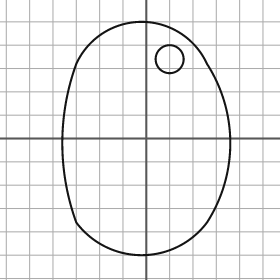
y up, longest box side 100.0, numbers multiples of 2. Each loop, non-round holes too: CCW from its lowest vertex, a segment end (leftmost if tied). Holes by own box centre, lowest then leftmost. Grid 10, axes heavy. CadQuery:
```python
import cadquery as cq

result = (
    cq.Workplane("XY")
    .moveTo(-30.0, -36.0)
    .threePointArc((-2.0, -50.0), (26.0, -36.0))
    .threePointArc((36.0, -2.0), (26.0, 32.0))
    .threePointArc((-2.0, 50.0), (-30.0, 32.0))
    .threePointArc((-36.0, -2.0), (-30.0, -36.0))
    .close()
    .moveTo(10.0, 34.0)
    .circle(6.0)
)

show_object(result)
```